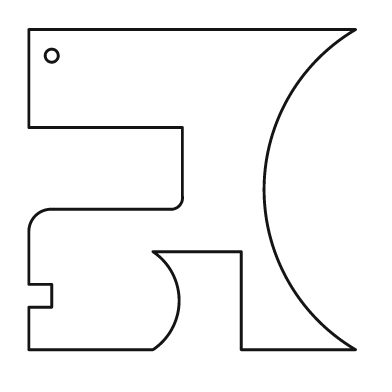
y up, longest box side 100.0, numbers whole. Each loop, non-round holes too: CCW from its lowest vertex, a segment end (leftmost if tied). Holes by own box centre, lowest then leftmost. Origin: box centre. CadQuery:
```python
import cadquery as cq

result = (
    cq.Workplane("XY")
    .moveTo(-50.0, -49.0)
    .lineTo(-12.0, -49.0)
    .threePointArc((-4.0, -34.0), (-12.0, -19.0))
    .lineTo(15.0, -19.0)
    .lineTo(15.0, -49.0)
    .lineTo(50.0, -49.0)
    .threePointArc((22.0, 0.0), (50.0, 49.0))
    .lineTo(-50.0, 49.0)
    .lineTo(-50.0, 19.0)
    .lineTo(-3.0, 19.0)
    .lineTo(-3.0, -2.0)
    .threePointArc((-4.0, -5.0), (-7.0, -6.0))
    .lineTo(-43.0, -6.0)
    .threePointArc((-48.0, -8.0), (-50.0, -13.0))
    .lineTo(-50.0, -29.0)
    .lineTo(-43.0, -29.0)
    .lineTo(-43.0, -36.0)
    .lineTo(-50.0, -36.0)
    .close()
    .moveTo(-43.0, 41.0)
    .circle(2.0)
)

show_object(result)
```